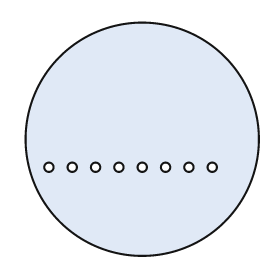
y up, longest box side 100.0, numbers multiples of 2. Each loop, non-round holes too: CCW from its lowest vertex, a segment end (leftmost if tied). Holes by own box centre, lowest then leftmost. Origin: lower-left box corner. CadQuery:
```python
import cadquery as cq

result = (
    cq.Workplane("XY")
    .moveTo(50.0, 50.0)
    .circle(50.0)
    .moveTo(10.0, 38.0)
    .circle(2.0)
    .moveTo(20.0, 38.0)
    .circle(2.0)
    .moveTo(30.0, 38.0)
    .circle(2.0)
    .moveTo(40.0, 38.0)
    .circle(2.0)
    .moveTo(50.0, 38.0)
    .circle(2.0)
    .moveTo(60.0, 38.0)
    .circle(2.0)
    .moveTo(70.0, 38.0)
    .circle(2.0)
    .moveTo(80.0, 38.0)
    .circle(2.0)
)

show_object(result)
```